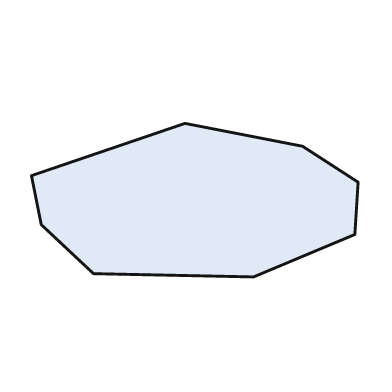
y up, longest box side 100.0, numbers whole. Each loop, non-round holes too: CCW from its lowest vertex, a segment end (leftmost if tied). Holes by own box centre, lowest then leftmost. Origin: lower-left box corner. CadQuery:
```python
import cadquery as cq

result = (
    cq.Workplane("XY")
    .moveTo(68.0, 0.0)
    .lineTo(99.0, 13.0)
    .lineTo(100.0, 29.0)
    .lineTo(83.0, 40.0)
    .lineTo(47.0, 47.0)
    .lineTo(0.0, 31.0)
    .lineTo(3.0, 16.0)
    .lineTo(19.0, 1.0)
    .close()
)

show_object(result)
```